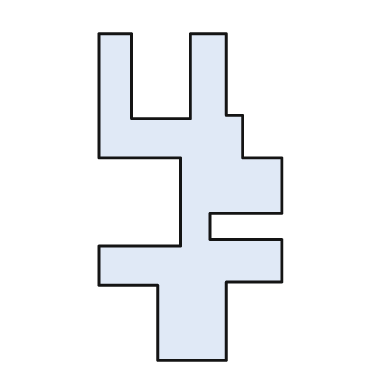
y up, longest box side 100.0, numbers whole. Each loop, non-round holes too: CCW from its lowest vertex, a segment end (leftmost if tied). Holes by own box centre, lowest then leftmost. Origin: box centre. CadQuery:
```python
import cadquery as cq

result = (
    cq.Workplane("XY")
    .moveTo(-10.0, -50.0)
    .lineTo(11.0, -50.0)
    .lineTo(11.0, -26.0)
    .lineTo(28.0, -26.0)
    .lineTo(28.0, -13.0)
    .lineTo(6.0, -13.0)
    .lineTo(6.0, -5.0)
    .lineTo(28.0, -5.0)
    .lineTo(28.0, 12.0)
    .lineTo(16.0, 12.0)
    .lineTo(16.0, 25.0)
    .lineTo(11.0, 25.0)
    .lineTo(11.0, 50.0)
    .lineTo(0.0, 50.0)
    .lineTo(0.0, 24.0)
    .lineTo(-18.0, 24.0)
    .lineTo(-18.0, 50.0)
    .lineTo(-28.0, 50.0)
    .lineTo(-28.0, 12.0)
    .lineTo(-3.0, 12.0)
    .lineTo(-3.0, -15.0)
    .lineTo(-28.0, -15.0)
    .lineTo(-28.0, -27.0)
    .lineTo(-10.0, -27.0)
    .close()
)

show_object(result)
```